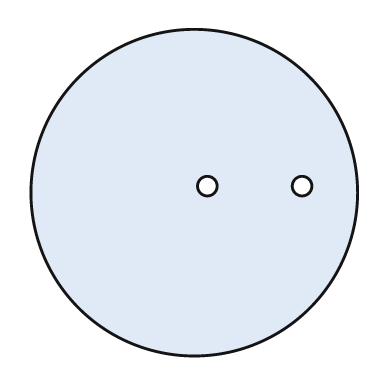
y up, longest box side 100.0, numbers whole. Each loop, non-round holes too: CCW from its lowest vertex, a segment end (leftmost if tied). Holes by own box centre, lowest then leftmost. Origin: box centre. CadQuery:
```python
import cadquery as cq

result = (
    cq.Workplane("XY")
    .moveTo(0.0, 0.0)
    .circle(50.0)
    .moveTo(4.0, 2.0)
    .circle(3.0)
    .moveTo(33.0, 2.0)
    .circle(3.0)
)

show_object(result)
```